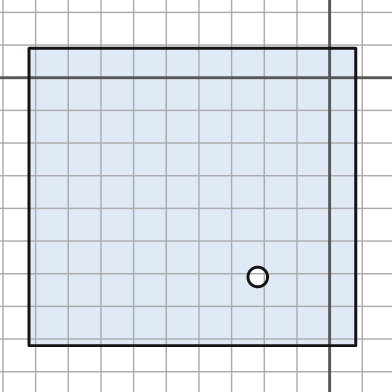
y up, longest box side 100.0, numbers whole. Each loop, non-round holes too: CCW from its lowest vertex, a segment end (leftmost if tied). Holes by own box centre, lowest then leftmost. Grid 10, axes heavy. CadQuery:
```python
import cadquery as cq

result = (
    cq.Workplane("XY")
    .moveTo(-92.0, -82.0)
    .lineTo(8.0, -82.0)
    .lineTo(8.0, 9.0)
    .lineTo(-92.0, 9.0)
    .close()
    .moveTo(-22.0, -61.0)
    .circle(3.0)
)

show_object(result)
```